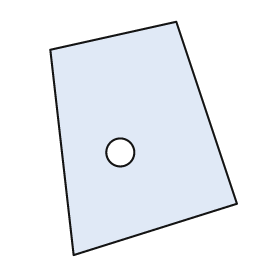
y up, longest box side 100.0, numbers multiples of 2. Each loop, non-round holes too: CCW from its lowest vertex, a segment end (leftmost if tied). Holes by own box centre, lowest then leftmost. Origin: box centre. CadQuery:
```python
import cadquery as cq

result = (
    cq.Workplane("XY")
    .moveTo(-30.0, -50.0)
    .lineTo(40.0, -28.0)
    .lineTo(14.0, 50.0)
    .lineTo(-40.0, 38.0)
    .close()
    .moveTo(-10.0, -6.0)
    .circle(6.0)
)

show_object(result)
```